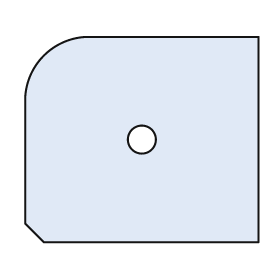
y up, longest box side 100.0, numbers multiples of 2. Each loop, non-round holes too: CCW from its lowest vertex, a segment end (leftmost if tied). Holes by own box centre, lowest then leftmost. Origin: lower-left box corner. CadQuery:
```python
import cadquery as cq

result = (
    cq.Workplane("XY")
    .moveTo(8.0, 0.0)
    .lineTo(100.0, 0.0)
    .lineTo(100.0, 88.0)
    .lineTo(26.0, 88.0)
    .threePointArc((8.0, 80.0), (0.0, 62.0))
    .lineTo(0.0, 8.0)
    .close()
    .moveTo(50.0, 44.0)
    .circle(6.0)
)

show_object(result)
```